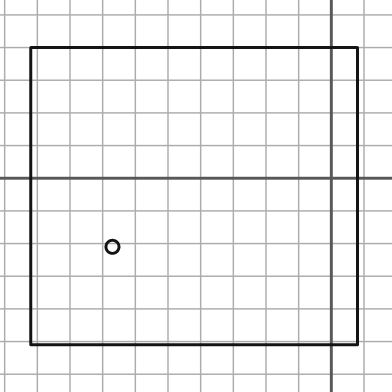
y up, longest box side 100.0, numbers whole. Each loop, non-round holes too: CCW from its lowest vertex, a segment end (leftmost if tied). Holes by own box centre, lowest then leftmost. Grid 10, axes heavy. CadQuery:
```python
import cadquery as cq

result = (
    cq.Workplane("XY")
    .moveTo(-92.0, -51.0)
    .lineTo(8.0, -51.0)
    .lineTo(8.0, 40.0)
    .lineTo(-92.0, 40.0)
    .close()
    .moveTo(-67.0, -21.0)
    .circle(2.0)
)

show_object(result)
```